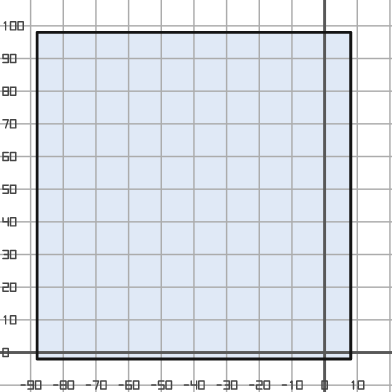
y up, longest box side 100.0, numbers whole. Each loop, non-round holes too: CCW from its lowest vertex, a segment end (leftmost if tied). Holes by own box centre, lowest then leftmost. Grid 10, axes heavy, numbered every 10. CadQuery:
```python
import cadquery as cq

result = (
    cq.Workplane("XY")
    .moveTo(-88.0, -2.0)
    .lineTo(8.0, -2.0)
    .lineTo(8.0, 98.0)
    .lineTo(-88.0, 98.0)
    .close()
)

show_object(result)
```